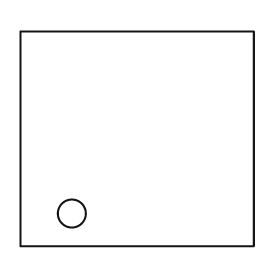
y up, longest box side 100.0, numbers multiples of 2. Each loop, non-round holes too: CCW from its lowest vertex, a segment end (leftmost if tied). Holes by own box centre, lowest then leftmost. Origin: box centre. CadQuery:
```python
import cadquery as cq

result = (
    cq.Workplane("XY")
    .moveTo(-50.0, -46.0)
    .lineTo(50.0, -46.0)
    .lineTo(50.0, 46.0)
    .lineTo(-50.0, 46.0)
    .close()
    .moveTo(-28.0, -32.0)
    .circle(6.0)
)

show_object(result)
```